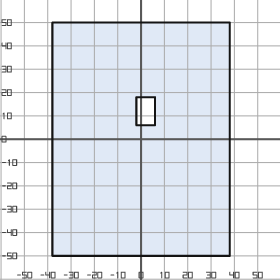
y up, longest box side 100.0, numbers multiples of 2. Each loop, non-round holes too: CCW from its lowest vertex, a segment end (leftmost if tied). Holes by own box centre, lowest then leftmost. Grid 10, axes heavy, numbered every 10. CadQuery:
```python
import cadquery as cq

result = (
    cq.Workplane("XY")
    .moveTo(-38.0, -50.0)
    .lineTo(38.0, -50.0)
    .lineTo(38.0, 50.0)
    .lineTo(-38.0, 50.0)
    .close()
    .moveTo(-2.0, 6.0)
    .lineTo(6.0, 6.0)
    .lineTo(6.0, 18.0)
    .lineTo(-2.0, 18.0)
    .close()
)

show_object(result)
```